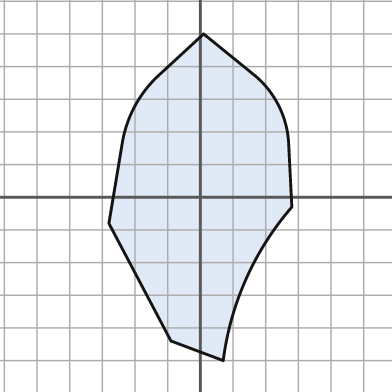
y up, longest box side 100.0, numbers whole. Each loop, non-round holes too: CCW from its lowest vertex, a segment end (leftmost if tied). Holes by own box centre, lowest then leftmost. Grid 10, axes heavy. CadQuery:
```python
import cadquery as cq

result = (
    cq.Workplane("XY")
    .moveTo(7.0, -50.0)
    .threePointArc((14.0, -25.0), (28.0, -3.0))
    .lineTo(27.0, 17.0)
    .threePointArc((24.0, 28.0), (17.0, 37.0))
    .lineTo(1.0, 50.0)
    .lineTo(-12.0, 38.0)
    .threePointArc((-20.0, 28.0), (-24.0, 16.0))
    .lineTo(-28.0, -8.0)
    .lineTo(-9.0, -44.0)
    .close()
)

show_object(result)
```